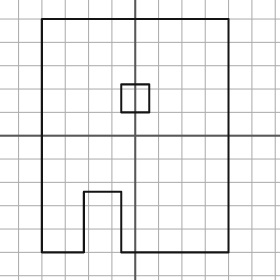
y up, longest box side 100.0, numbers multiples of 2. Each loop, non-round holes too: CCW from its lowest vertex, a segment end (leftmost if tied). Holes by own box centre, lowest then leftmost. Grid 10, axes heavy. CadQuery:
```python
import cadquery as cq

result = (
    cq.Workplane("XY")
    .moveTo(-40.0, -50.0)
    .lineTo(-22.0, -50.0)
    .lineTo(-22.0, -24.0)
    .lineTo(-6.0, -24.0)
    .lineTo(-6.0, -50.0)
    .lineTo(40.0, -50.0)
    .lineTo(40.0, 50.0)
    .lineTo(-40.0, 50.0)
    .close()
    .moveTo(-6.0, 10.0)
    .lineTo(6.0, 10.0)
    .lineTo(6.0, 22.0)
    .lineTo(-6.0, 22.0)
    .close()
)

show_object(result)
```